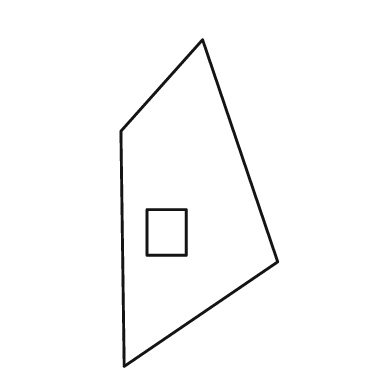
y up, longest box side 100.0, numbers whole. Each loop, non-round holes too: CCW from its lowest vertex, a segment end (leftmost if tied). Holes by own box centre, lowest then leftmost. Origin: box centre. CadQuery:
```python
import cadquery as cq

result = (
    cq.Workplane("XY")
    .moveTo(-23.0, -50.0)
    .lineTo(24.0, -18.0)
    .lineTo(1.0, 50.0)
    .lineTo(-24.0, 22.0)
    .close()
    .moveTo(-16.0, -16.0)
    .lineTo(-4.0, -16.0)
    .lineTo(-4.0, -2.0)
    .lineTo(-16.0, -2.0)
    .close()
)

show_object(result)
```